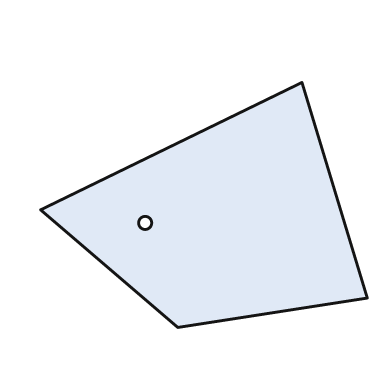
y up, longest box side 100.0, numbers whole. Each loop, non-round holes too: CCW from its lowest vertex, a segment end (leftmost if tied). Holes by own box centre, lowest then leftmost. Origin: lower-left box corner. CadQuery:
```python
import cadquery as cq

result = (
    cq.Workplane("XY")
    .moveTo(42.0, 0.0)
    .lineTo(100.0, 9.0)
    .lineTo(80.0, 75.0)
    .lineTo(0.0, 36.0)
    .close()
    .moveTo(32.0, 32.0)
    .circle(2.0)
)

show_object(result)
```